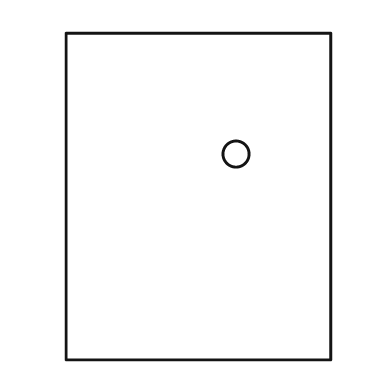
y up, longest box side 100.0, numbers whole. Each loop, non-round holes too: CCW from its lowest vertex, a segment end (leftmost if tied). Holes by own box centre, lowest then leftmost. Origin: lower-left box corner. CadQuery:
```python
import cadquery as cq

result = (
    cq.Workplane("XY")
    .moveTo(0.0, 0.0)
    .lineTo(81.0, 0.0)
    .lineTo(81.0, 100.0)
    .lineTo(0.0, 100.0)
    .close()
    .moveTo(52.0, 63.0)
    .circle(4.0)
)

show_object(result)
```